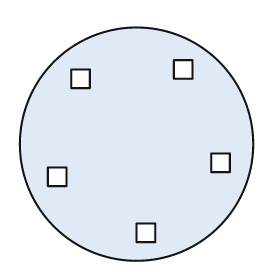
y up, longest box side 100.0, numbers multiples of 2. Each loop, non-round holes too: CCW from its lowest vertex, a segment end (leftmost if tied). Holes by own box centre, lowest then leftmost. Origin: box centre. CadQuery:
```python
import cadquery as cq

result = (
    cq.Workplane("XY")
    .moveTo(0.0, 0.0)
    .circle(50.0)
    .moveTo(0.0, -42.0)
    .lineTo(8.0, -42.0)
    .lineTo(8.0, -34.0)
    .lineTo(0.0, -34.0)
    .close()
    .moveTo(-38.0, -18.0)
    .lineTo(-30.0, -18.0)
    .lineTo(-30.0, -10.0)
    .lineTo(-38.0, -10.0)
    .close()
    .moveTo(32.0, -12.0)
    .lineTo(40.0, -12.0)
    .lineTo(40.0, -4.0)
    .lineTo(32.0, -4.0)
    .close()
    .moveTo(-28.0, 24.0)
    .lineTo(-20.0, 24.0)
    .lineTo(-20.0, 32.0)
    .lineTo(-28.0, 32.0)
    .close()
    .moveTo(16.0, 28.0)
    .lineTo(24.0, 28.0)
    .lineTo(24.0, 36.0)
    .lineTo(16.0, 36.0)
    .close()
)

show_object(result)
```